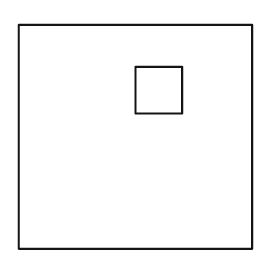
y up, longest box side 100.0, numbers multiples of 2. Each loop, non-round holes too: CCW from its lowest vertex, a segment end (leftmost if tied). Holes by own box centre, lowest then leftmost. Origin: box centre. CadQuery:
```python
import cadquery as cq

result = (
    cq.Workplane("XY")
    .moveTo(-50.0, -48.0)
    .lineTo(50.0, -48.0)
    .lineTo(50.0, 48.0)
    .lineTo(-50.0, 48.0)
    .close()
    .moveTo(0.0, 10.0)
    .lineTo(20.0, 10.0)
    .lineTo(20.0, 30.0)
    .lineTo(0.0, 30.0)
    .close()
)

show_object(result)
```